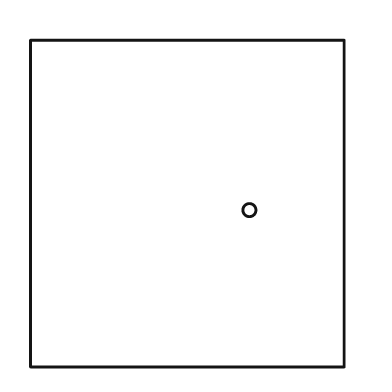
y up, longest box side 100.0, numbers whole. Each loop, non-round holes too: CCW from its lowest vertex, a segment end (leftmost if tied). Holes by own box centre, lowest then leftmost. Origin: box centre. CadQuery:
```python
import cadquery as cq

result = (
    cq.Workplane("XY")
    .moveTo(-48.0, -50.0)
    .lineTo(48.0, -50.0)
    .lineTo(48.0, 50.0)
    .lineTo(-48.0, 50.0)
    .close()
    .moveTo(19.0, -2.0)
    .circle(2.0)
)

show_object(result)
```